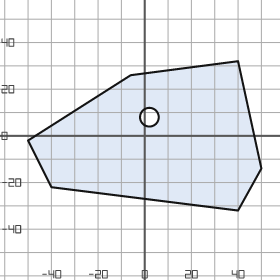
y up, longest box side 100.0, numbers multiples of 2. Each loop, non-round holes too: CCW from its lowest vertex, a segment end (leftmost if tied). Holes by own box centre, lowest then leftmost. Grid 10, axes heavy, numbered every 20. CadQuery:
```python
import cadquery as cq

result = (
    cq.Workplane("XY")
    .moveTo(40.0, -32.0)
    .lineTo(50.0, -14.0)
    .lineTo(40.0, 32.0)
    .lineTo(-6.0, 26.0)
    .lineTo(-50.0, -2.0)
    .lineTo(-40.0, -22.0)
    .close()
    .moveTo(2.0, 8.0)
    .circle(4.0)
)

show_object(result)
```